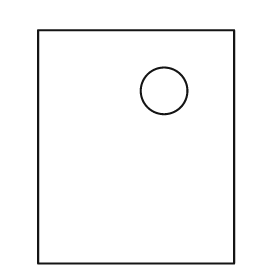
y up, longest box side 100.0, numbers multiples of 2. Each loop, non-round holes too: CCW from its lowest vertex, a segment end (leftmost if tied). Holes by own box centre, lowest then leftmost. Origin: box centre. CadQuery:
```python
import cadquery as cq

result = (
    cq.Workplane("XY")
    .moveTo(-42.0, -50.0)
    .lineTo(42.0, -50.0)
    .lineTo(42.0, 50.0)
    .lineTo(-42.0, 50.0)
    .close()
    .moveTo(12.0, 24.0)
    .circle(10.0)
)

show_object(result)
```